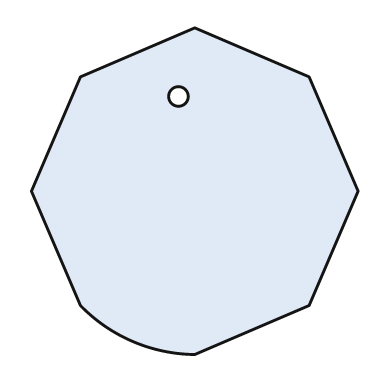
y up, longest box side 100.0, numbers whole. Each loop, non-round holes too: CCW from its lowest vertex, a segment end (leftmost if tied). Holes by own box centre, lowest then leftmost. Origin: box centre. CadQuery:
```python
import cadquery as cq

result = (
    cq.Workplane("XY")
    .moveTo(0.0, -50.0)
    .lineTo(35.0, -35.0)
    .lineTo(50.0, 0.0)
    .lineTo(35.0, 35.0)
    .lineTo(0.0, 50.0)
    .lineTo(-35.0, 35.0)
    .lineTo(-50.0, 0.0)
    .lineTo(-35.0, -35.0)
    .threePointArc((-19.0, -46.0), (0.0, -50.0))
    .close()
    .moveTo(-5.0, 29.0)
    .circle(3.0)
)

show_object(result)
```